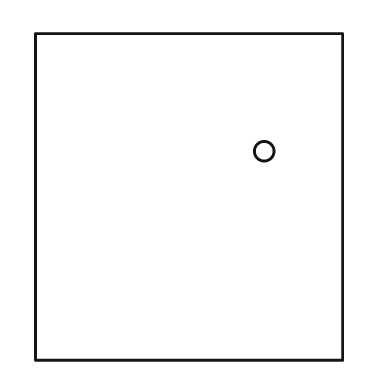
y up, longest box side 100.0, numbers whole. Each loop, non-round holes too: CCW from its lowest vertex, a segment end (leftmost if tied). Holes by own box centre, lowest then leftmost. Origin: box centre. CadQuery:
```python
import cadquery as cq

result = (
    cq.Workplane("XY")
    .moveTo(-47.0, -50.0)
    .lineTo(47.0, -50.0)
    .lineTo(47.0, 50.0)
    .lineTo(-47.0, 50.0)
    .close()
    .moveTo(23.0, 14.0)
    .circle(3.0)
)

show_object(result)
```